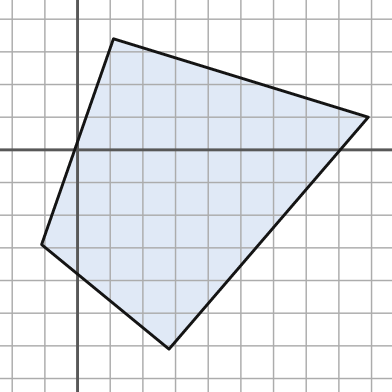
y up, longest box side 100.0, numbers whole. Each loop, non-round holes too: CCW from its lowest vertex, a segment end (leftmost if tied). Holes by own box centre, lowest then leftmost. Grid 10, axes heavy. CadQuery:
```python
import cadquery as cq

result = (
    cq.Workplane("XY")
    .moveTo(28.0, -61.0)
    .lineTo(89.0, 10.0)
    .lineTo(11.0, 34.0)
    .lineTo(-11.0, -29.0)
    .close()
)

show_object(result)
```